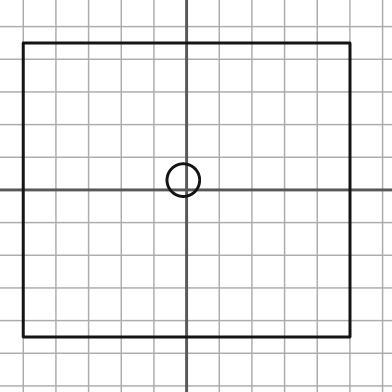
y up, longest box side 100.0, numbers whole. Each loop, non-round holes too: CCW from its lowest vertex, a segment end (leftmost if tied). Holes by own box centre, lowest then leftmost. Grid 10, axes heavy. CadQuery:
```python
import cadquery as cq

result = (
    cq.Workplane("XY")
    .moveTo(-50.0, -45.0)
    .lineTo(50.0, -45.0)
    .lineTo(50.0, 45.0)
    .lineTo(-50.0, 45.0)
    .close()
    .moveTo(-1.0, 3.0)
    .circle(5.0)
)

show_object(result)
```